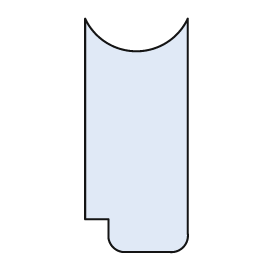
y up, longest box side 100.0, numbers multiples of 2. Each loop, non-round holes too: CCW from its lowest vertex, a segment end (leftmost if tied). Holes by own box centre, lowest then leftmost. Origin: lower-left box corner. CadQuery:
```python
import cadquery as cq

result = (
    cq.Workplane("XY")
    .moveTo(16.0, 0.0)
    .lineTo(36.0, 0.0)
    .threePointArc((42.0, 2.0), (44.0, 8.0))
    .lineTo(44.0, 100.0)
    .threePointArc((22.0, 86.0), (0.0, 100.0))
    .lineTo(0.0, 14.0)
    .lineTo(10.0, 14.0)
    .lineTo(10.0, 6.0)
    .threePointArc((12.0, 2.0), (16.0, 0.0))
    .close()
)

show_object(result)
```